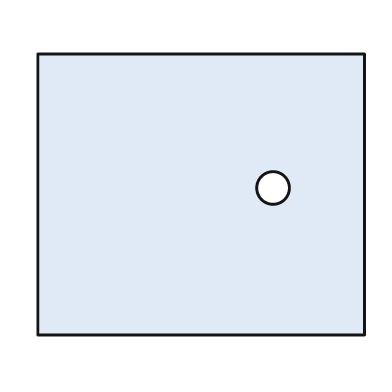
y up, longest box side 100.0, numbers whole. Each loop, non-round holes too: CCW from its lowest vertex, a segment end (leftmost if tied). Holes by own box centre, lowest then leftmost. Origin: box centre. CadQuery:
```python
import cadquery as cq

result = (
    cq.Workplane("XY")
    .moveTo(-50.0, -43.0)
    .lineTo(50.0, -43.0)
    .lineTo(50.0, 43.0)
    .lineTo(-50.0, 43.0)
    .close()
    .moveTo(22.0, 2.0)
    .circle(5.0)
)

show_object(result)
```